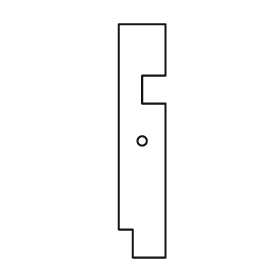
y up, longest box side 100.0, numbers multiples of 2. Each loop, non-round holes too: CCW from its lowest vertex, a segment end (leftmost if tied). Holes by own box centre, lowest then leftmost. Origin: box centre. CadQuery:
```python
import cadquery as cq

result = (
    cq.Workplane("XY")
    .moveTo(-4.0, -50.0)
    .lineTo(10.0, -50.0)
    .lineTo(10.0, 16.0)
    .lineTo(0.0, 16.0)
    .lineTo(0.0, 28.0)
    .lineTo(10.0, 28.0)
    .lineTo(10.0, 50.0)
    .lineTo(-10.0, 50.0)
    .lineTo(-10.0, -38.0)
    .lineTo(-4.0, -38.0)
    .close()
    .moveTo(0.0, 0.0)
    .circle(2.0)
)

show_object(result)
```